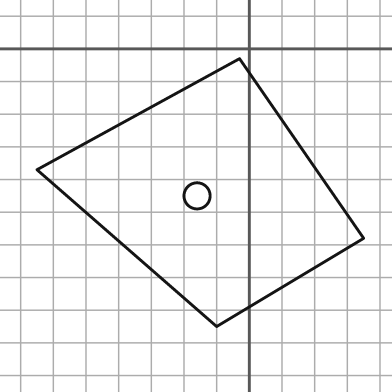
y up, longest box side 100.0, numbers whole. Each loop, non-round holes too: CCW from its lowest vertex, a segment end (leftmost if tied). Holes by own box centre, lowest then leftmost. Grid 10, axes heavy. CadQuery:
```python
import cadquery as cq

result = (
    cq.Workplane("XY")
    .moveTo(-10.0, -85.0)
    .lineTo(35.0, -58.0)
    .lineTo(-3.0, -3.0)
    .lineTo(-65.0, -37.0)
    .close()
    .moveTo(-16.0, -45.0)
    .circle(4.0)
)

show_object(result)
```